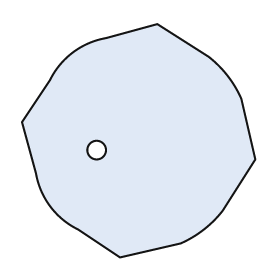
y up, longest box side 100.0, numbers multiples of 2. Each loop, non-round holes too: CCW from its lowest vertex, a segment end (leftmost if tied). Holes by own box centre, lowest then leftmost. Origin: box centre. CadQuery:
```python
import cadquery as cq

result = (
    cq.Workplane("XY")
    .moveTo(-8.0, -50.0)
    .lineTo(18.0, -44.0)
    .threePointArc((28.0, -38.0), (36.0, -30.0))
    .lineTo(50.0, -8.0)
    .lineTo(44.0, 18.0)
    .threePointArc((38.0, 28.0), (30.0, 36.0))
    .lineTo(8.0, 50.0)
    .lineTo(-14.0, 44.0)
    .threePointArc((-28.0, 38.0), (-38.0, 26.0))
    .lineTo(-50.0, 8.0)
    .lineTo(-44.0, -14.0)
    .threePointArc((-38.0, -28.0), (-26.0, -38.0))
    .close()
    .moveTo(-18.0, -4.0)
    .circle(4.0)
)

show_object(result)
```